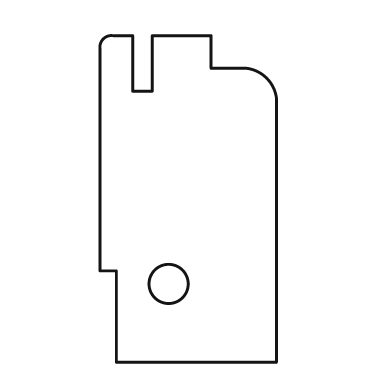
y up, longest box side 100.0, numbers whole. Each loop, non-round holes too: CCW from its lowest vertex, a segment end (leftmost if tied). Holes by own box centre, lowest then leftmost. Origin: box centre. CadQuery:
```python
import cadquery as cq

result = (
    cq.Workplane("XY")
    .moveTo(-22.0, -50.0)
    .lineTo(27.0, -50.0)
    .lineTo(27.0, 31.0)
    .threePointArc((24.0, 37.0), (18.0, 40.0))
    .lineTo(7.0, 40.0)
    .lineTo(7.0, 50.0)
    .lineTo(-11.0, 50.0)
    .lineTo(-11.0, 33.0)
    .lineTo(-17.0, 33.0)
    .lineTo(-17.0, 50.0)
    .lineTo(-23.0, 50.0)
    .threePointArc((-26.0, 49.0), (-27.0, 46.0))
    .lineTo(-27.0, -22.0)
    .lineTo(-22.0, -22.0)
    .close()
    .moveTo(-6.0, -26.0)
    .circle(6.0)
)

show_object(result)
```